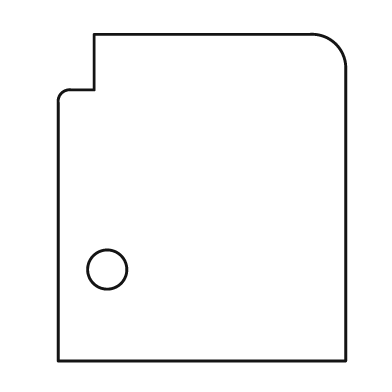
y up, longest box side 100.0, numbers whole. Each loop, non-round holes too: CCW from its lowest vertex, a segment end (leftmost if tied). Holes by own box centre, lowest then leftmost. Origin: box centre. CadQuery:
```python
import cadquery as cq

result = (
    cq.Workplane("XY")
    .moveTo(-44.0, -50.0)
    .lineTo(44.0, -50.0)
    .lineTo(44.0, 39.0)
    .threePointArc((41.0, 47.0), (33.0, 50.0))
    .lineTo(-33.0, 50.0)
    .lineTo(-33.0, 33.0)
    .lineTo(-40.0, 33.0)
    .threePointArc((-43.0, 32.0), (-44.0, 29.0))
    .close()
    .moveTo(-29.0, -22.0)
    .circle(6.0)
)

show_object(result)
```